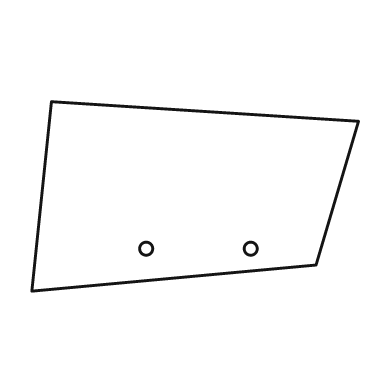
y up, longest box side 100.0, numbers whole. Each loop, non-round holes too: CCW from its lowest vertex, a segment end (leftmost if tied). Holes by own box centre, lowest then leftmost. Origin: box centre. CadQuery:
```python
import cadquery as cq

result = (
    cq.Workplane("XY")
    .moveTo(-50.0, -29.0)
    .lineTo(37.0, -21.0)
    .lineTo(50.0, 23.0)
    .lineTo(-44.0, 29.0)
    .close()
    .moveTo(-15.0, -16.0)
    .circle(2.0)
    .moveTo(17.0, -16.0)
    .circle(2.0)
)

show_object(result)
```